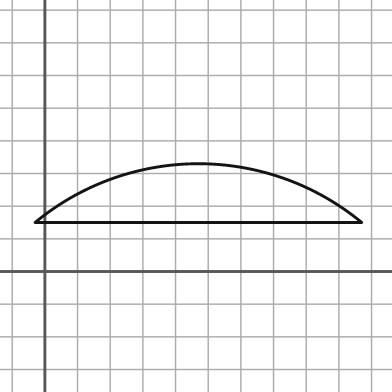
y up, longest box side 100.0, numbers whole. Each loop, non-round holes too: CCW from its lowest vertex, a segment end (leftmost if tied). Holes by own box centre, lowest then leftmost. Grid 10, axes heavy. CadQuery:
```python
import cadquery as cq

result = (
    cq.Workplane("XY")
    .moveTo(-3.0, 15.0)
    .lineTo(97.0, 15.0)
    .threePointArc((47.0, 33.0), (-3.0, 15.0))
    .close()
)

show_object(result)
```